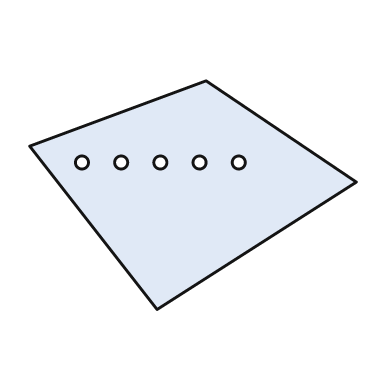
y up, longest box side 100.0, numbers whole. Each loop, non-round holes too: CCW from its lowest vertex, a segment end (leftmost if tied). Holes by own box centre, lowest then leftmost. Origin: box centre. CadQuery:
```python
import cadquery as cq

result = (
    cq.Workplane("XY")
    .moveTo(-11.0, -35.0)
    .lineTo(50.0, 4.0)
    .lineTo(4.0, 35.0)
    .lineTo(-50.0, 15.0)
    .close()
    .moveTo(-34.0, 10.0)
    .circle(2.0)
    .moveTo(-22.0, 10.0)
    .circle(2.0)
    .moveTo(-10.0, 10.0)
    .circle(2.0)
    .moveTo(2.0, 10.0)
    .circle(2.0)
    .moveTo(14.0, 10.0)
    .circle(2.0)
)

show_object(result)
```